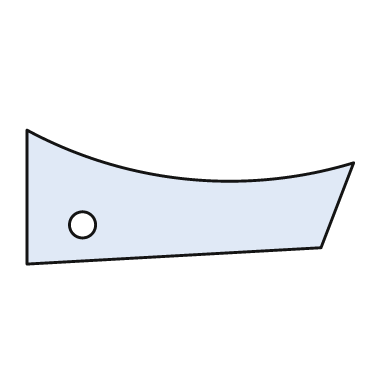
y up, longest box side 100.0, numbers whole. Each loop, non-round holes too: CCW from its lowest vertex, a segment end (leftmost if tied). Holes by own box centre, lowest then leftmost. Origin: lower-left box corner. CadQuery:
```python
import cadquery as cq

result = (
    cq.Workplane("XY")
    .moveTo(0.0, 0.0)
    .lineTo(90.0, 5.0)
    .lineTo(100.0, 31.0)
    .threePointArc((49.0, 26.0), (0.0, 41.0))
    .close()
    .moveTo(17.0, 12.0)
    .circle(4.0)
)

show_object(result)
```